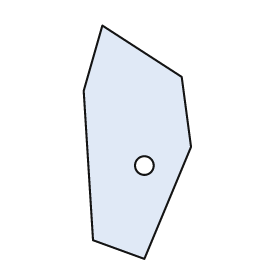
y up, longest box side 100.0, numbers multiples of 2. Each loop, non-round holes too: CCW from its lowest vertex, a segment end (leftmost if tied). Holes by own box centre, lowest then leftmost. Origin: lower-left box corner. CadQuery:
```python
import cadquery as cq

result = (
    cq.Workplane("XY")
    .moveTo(26.0, 0.0)
    .lineTo(46.0, 48.0)
    .lineTo(42.0, 78.0)
    .lineTo(8.0, 100.0)
    .lineTo(0.0, 72.0)
    .lineTo(4.0, 8.0)
    .close()
    .moveTo(26.0, 40.0)
    .circle(4.0)
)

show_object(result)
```